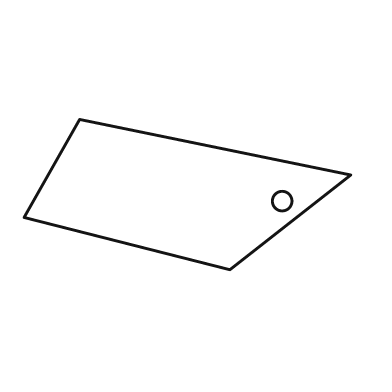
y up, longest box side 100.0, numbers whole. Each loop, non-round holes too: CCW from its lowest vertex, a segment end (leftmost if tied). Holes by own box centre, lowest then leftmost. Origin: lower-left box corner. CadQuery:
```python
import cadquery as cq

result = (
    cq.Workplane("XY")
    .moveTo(63.0, 0.0)
    .lineTo(100.0, 29.0)
    .lineTo(17.0, 46.0)
    .lineTo(0.0, 16.0)
    .close()
    .moveTo(79.0, 21.0)
    .circle(3.0)
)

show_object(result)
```